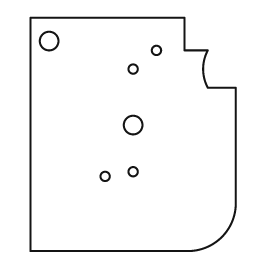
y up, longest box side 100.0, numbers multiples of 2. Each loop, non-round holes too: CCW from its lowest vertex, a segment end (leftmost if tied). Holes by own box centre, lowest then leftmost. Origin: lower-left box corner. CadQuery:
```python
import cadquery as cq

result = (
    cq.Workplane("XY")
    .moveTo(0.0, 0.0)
    .lineTo(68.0, 0.0)
    .threePointArc((82.0, 6.0), (88.0, 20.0))
    .lineTo(88.0, 70.0)
    .lineTo(76.0, 70.0)
    .threePointArc((74.0, 78.0), (76.0, 86.0))
    .lineTo(66.0, 86.0)
    .lineTo(66.0, 100.0)
    .lineTo(0.0, 100.0)
    .close()
    .moveTo(32.0, 32.0)
    .circle(2.0)
    .moveTo(44.0, 34.0)
    .circle(2.0)
    .moveTo(44.0, 54.0)
    .circle(4.0)
    .moveTo(44.0, 78.0)
    .circle(2.0)
    .moveTo(54.0, 86.0)
    .circle(2.0)
    .moveTo(8.0, 90.0)
    .circle(4.0)
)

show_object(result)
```